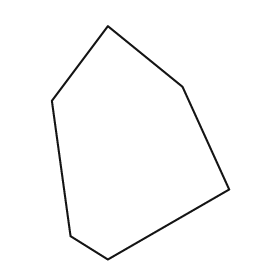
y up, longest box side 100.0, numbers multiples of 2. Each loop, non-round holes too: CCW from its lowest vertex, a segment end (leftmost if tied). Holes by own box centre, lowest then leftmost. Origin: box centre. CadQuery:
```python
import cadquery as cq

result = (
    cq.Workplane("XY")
    .moveTo(-14.0, -50.0)
    .lineTo(38.0, -20.0)
    .lineTo(18.0, 24.0)
    .lineTo(-14.0, 50.0)
    .lineTo(-38.0, 18.0)
    .lineTo(-30.0, -40.0)
    .close()
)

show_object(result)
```